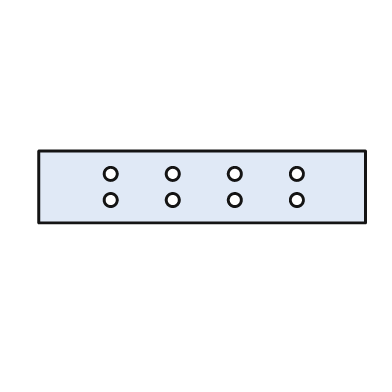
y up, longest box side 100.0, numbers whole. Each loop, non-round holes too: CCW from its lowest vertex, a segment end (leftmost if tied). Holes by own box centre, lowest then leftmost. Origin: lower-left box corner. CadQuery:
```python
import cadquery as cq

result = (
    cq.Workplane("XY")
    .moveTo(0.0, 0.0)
    .lineTo(100.0, 0.0)
    .lineTo(100.0, 22.0)
    .lineTo(0.0, 22.0)
    .close()
    .moveTo(22.0, 7.0)
    .circle(2.0)
    .moveTo(41.0, 7.0)
    .circle(2.0)
    .moveTo(60.0, 7.0)
    .circle(2.0)
    .moveTo(79.0, 7.0)
    .circle(2.0)
    .moveTo(22.0, 15.0)
    .circle(2.0)
    .moveTo(41.0, 15.0)
    .circle(2.0)
    .moveTo(60.0, 15.0)
    .circle(2.0)
    .moveTo(79.0, 15.0)
    .circle(2.0)
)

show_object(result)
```